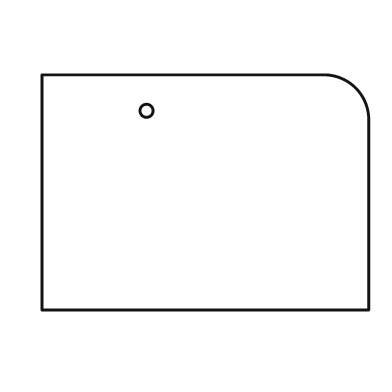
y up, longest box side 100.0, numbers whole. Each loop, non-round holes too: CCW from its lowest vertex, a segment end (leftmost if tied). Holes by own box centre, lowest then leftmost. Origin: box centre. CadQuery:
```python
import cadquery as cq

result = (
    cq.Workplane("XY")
    .moveTo(-50.0, -36.0)
    .lineTo(50.0, -36.0)
    .lineTo(50.0, 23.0)
    .threePointArc((46.0, 32.0), (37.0, 36.0))
    .lineTo(-50.0, 36.0)
    .close()
    .moveTo(-18.0, 25.0)
    .circle(2.0)
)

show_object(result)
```